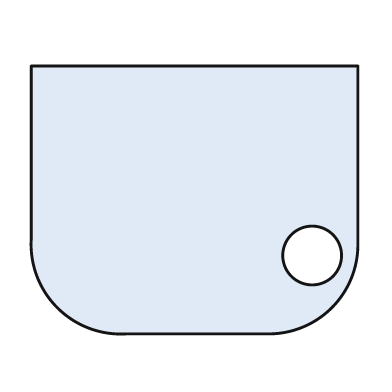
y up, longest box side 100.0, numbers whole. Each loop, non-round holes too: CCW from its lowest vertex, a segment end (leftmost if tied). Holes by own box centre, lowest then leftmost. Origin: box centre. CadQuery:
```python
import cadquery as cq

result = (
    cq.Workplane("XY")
    .moveTo(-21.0, -41.0)
    .lineTo(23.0, -41.0)
    .threePointArc((42.0, -33.0), (50.0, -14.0))
    .lineTo(50.0, 41.0)
    .lineTo(-50.0, 41.0)
    .lineTo(-50.0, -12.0)
    .threePointArc((-42.0, -33.0), (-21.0, -41.0))
    .close()
    .moveTo(36.0, -17.0)
    .circle(9.0)
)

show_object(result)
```